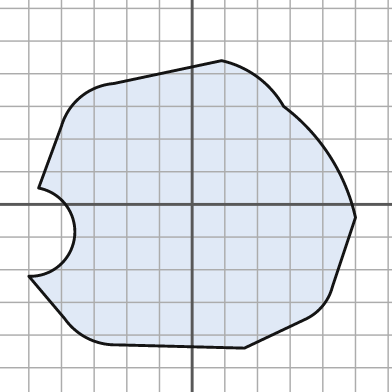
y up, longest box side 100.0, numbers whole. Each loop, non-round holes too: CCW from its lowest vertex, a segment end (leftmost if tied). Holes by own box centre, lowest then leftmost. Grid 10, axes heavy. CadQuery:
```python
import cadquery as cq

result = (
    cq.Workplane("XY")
    .moveTo(16.0, -44.0)
    .lineTo(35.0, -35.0)
    .threePointArc((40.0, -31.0), (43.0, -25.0))
    .lineTo(50.0, -4.0)
    .threePointArc((42.0, 15.0), (28.0, 30.0))
    .threePointArc((20.0, 39.0), (9.0, 44.0))
    .lineTo(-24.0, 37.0)
    .threePointArc((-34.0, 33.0), (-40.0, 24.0))
    .lineTo(-47.0, 5.0)
    .threePointArc((-36.0, -10.0), (-50.0, -22.0))
    .lineTo(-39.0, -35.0)
    .threePointArc((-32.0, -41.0), (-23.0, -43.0))
    .close()
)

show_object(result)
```